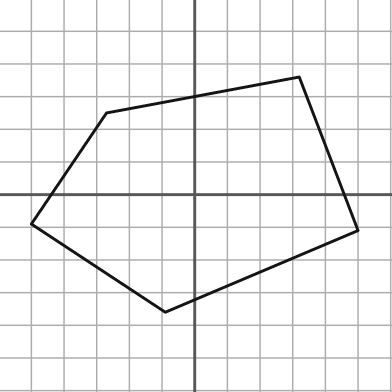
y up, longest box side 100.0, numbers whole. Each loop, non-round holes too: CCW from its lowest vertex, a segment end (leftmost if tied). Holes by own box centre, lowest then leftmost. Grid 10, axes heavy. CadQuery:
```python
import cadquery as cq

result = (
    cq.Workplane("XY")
    .moveTo(-9.0, -36.0)
    .lineTo(50.0, -11.0)
    .lineTo(32.0, 36.0)
    .lineTo(-27.0, 25.0)
    .lineTo(-50.0, -9.0)
    .close()
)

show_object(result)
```